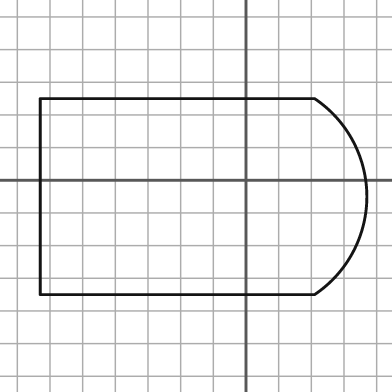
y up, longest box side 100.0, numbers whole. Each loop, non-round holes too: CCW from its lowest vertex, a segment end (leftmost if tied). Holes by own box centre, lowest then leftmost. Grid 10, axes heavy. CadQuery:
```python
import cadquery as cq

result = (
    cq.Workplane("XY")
    .moveTo(-63.0, -35.0)
    .lineTo(21.0, -35.0)
    .threePointArc((37.0, -5.0), (21.0, 25.0))
    .lineTo(-63.0, 25.0)
    .close()
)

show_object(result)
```